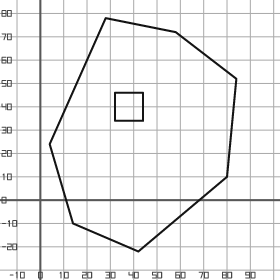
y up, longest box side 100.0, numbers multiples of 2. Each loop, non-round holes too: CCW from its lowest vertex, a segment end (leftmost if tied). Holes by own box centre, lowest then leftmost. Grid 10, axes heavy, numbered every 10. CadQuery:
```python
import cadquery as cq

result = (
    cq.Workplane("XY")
    .moveTo(42.0, -22.0)
    .lineTo(80.0, 10.0)
    .lineTo(84.0, 52.0)
    .lineTo(58.0, 72.0)
    .lineTo(28.0, 78.0)
    .lineTo(4.0, 24.0)
    .lineTo(14.0, -10.0)
    .close()
    .moveTo(32.0, 34.0)
    .lineTo(44.0, 34.0)
    .lineTo(44.0, 46.0)
    .lineTo(32.0, 46.0)
    .close()
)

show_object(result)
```